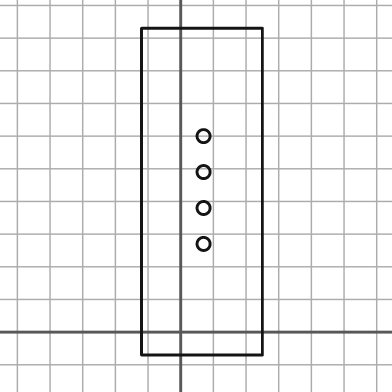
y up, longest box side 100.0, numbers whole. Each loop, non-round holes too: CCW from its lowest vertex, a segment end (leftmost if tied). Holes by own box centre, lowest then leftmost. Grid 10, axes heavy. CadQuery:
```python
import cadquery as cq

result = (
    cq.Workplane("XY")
    .moveTo(-12.0, -7.0)
    .lineTo(25.0, -7.0)
    .lineTo(25.0, 93.0)
    .lineTo(-12.0, 93.0)
    .close()
    .moveTo(7.0, 27.0)
    .circle(2.0)
    .moveTo(7.0, 38.0)
    .circle(2.0)
    .moveTo(7.0, 49.0)
    .circle(2.0)
    .moveTo(7.0, 60.0)
    .circle(2.0)
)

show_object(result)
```